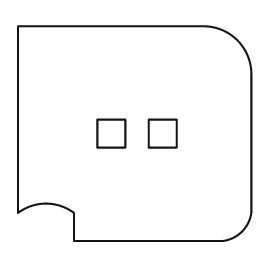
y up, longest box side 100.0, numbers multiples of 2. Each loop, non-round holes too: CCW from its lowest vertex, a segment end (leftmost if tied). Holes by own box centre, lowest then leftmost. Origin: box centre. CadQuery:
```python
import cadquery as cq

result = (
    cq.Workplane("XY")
    .moveTo(-26.0, -46.0)
    .lineTo(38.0, -46.0)
    .threePointArc((46.0, -42.0), (50.0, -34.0))
    .lineTo(50.0, 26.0)
    .threePointArc((44.0, 40.0), (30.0, 46.0))
    .lineTo(-50.0, 46.0)
    .lineTo(-50.0, -34.0)
    .threePointArc((-38.0, -30.0), (-26.0, -34.0))
    .close()
    .moveTo(-16.0, -6.0)
    .lineTo(-4.0, -6.0)
    .lineTo(-4.0, 6.0)
    .lineTo(-16.0, 6.0)
    .close()
    .moveTo(6.0, -6.0)
    .lineTo(18.0, -6.0)
    .lineTo(18.0, 6.0)
    .lineTo(6.0, 6.0)
    .close()
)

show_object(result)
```